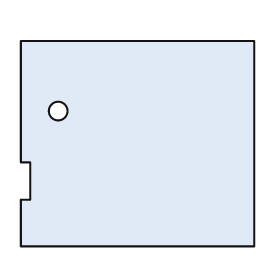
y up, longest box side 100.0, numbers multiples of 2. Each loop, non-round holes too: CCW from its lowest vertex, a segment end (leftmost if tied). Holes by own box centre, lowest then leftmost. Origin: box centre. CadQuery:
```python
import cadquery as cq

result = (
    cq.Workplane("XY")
    .moveTo(-50.0, -44.0)
    .lineTo(50.0, -44.0)
    .lineTo(50.0, 44.0)
    .lineTo(-50.0, 44.0)
    .lineTo(-50.0, -8.0)
    .lineTo(-46.0, -8.0)
    .lineTo(-46.0, -24.0)
    .lineTo(-50.0, -24.0)
    .close()
    .moveTo(-34.0, 14.0)
    .circle(4.0)
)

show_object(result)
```